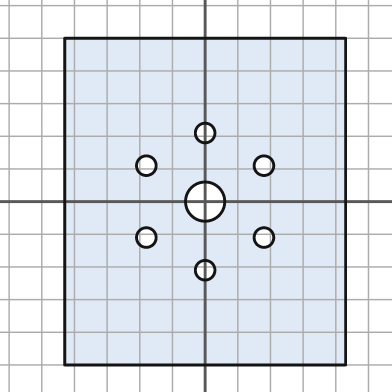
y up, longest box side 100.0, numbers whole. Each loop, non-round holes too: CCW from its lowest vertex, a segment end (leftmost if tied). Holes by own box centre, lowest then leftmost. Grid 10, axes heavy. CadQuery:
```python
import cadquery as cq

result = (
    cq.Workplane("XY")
    .moveTo(-43.0, -50.0)
    .lineTo(43.0, -50.0)
    .lineTo(43.0, 50.0)
    .lineTo(-43.0, 50.0)
    .close()
    .moveTo(0.0, -21.0)
    .circle(3.0)
    .moveTo(-18.0, -11.0)
    .circle(3.0)
    .moveTo(18.0, -11.0)
    .circle(3.0)
    .moveTo(0.0, 0.0)
    .circle(6.0)
    .moveTo(-18.0, 11.0)
    .circle(3.0)
    .moveTo(18.0, 11.0)
    .circle(3.0)
    .moveTo(0.0, 21.0)
    .circle(3.0)
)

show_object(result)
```